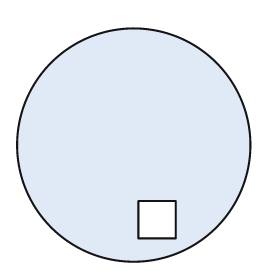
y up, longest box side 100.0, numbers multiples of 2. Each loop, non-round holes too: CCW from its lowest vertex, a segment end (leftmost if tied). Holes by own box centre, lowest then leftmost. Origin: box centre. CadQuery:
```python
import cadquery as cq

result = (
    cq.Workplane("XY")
    .moveTo(0.0, 0.0)
    .circle(50.0)
    .moveTo(2.0, -40.0)
    .lineTo(18.0, -40.0)
    .lineTo(18.0, -24.0)
    .lineTo(2.0, -24.0)
    .close()
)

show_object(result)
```